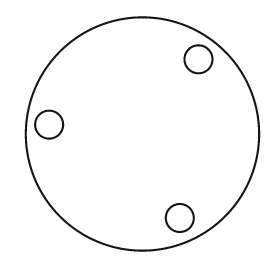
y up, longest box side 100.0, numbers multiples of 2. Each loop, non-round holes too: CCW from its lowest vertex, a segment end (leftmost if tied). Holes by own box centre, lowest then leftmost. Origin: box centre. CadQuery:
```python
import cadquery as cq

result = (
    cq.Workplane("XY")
    .moveTo(0.0, 0.0)
    .circle(50.0)
    .moveTo(16.0, -36.0)
    .circle(6.0)
    .moveTo(-40.0, 4.0)
    .circle(6.0)
    .moveTo(24.0, 32.0)
    .circle(6.0)
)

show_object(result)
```